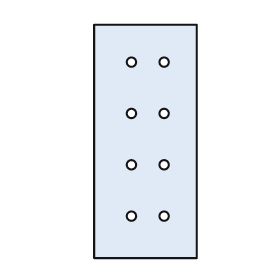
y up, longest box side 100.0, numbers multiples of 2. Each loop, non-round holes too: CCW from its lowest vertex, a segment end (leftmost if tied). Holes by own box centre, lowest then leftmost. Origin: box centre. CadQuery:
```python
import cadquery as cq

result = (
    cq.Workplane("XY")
    .moveTo(-22.0, -50.0)
    .lineTo(22.0, -50.0)
    .lineTo(22.0, 50.0)
    .lineTo(-22.0, 50.0)
    .close()
    .moveTo(-6.0, -32.0)
    .circle(2.0)
    .moveTo(8.0, -32.0)
    .circle(2.0)
    .moveTo(-6.0, -10.0)
    .circle(2.0)
    .moveTo(8.0, -10.0)
    .circle(2.0)
    .moveTo(-6.0, 12.0)
    .circle(2.0)
    .moveTo(8.0, 12.0)
    .circle(2.0)
    .moveTo(-6.0, 34.0)
    .circle(2.0)
    .moveTo(8.0, 34.0)
    .circle(2.0)
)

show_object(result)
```